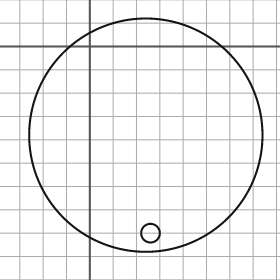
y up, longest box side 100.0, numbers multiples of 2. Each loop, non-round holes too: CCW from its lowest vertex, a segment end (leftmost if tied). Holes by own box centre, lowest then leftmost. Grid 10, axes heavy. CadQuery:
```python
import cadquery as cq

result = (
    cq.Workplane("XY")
    .moveTo(24.0, -38.0)
    .circle(50.0)
    .moveTo(26.0, -80.0)
    .circle(4.0)
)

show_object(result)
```